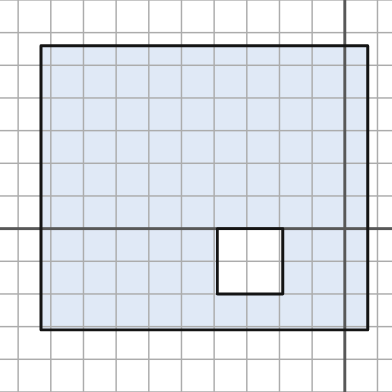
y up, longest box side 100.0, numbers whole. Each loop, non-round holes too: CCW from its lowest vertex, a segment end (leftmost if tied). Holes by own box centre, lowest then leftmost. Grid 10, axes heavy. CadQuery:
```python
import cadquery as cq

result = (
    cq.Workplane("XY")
    .moveTo(-93.0, -31.0)
    .lineTo(7.0, -31.0)
    .lineTo(7.0, 56.0)
    .lineTo(-93.0, 56.0)
    .close()
    .moveTo(-39.0, -20.0)
    .lineTo(-19.0, -20.0)
    .lineTo(-19.0, 0.0)
    .lineTo(-39.0, 0.0)
    .close()
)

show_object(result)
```